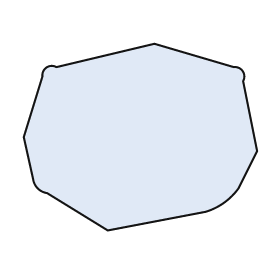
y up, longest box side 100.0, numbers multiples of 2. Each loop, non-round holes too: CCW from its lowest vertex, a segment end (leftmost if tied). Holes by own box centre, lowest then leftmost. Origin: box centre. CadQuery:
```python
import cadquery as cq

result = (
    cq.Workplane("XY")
    .moveTo(-14.0, -40.0)
    .lineTo(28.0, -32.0)
    .threePointArc((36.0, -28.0), (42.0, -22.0))
    .lineTo(50.0, -6.0)
    .lineTo(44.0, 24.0)
    .threePointArc((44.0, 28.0), (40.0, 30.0))
    .lineTo(6.0, 40.0)
    .lineTo(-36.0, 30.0)
    .threePointArc((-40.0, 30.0), (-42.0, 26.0))
    .lineTo(-50.0, 0.0)
    .lineTo(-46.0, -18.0)
    .threePointArc((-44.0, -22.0), (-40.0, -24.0))
    .close()
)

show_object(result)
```